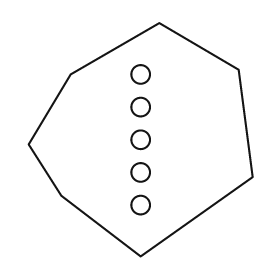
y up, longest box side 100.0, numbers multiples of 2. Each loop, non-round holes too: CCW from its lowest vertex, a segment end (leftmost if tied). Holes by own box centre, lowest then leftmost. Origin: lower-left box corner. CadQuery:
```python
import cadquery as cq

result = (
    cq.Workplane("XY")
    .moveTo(48.0, 0.0)
    .lineTo(96.0, 34.0)
    .lineTo(90.0, 80.0)
    .lineTo(56.0, 100.0)
    .lineTo(18.0, 78.0)
    .lineTo(0.0, 48.0)
    .lineTo(14.0, 26.0)
    .close()
    .moveTo(48.0, 22.0)
    .circle(4.0)
    .moveTo(48.0, 36.0)
    .circle(4.0)
    .moveTo(48.0, 50.0)
    .circle(4.0)
    .moveTo(48.0, 64.0)
    .circle(4.0)
    .moveTo(48.0, 78.0)
    .circle(4.0)
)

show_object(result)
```